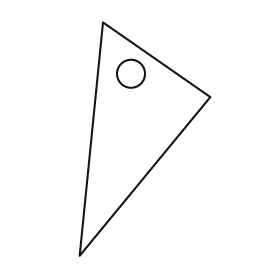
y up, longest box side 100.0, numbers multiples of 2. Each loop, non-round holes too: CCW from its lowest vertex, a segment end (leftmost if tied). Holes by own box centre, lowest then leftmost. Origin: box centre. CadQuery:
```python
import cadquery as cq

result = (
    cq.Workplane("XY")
    .moveTo(-28.0, -50.0)
    .lineTo(28.0, 18.0)
    .lineTo(-18.0, 50.0)
    .close()
    .moveTo(-6.0, 28.0)
    .circle(6.0)
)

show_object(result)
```